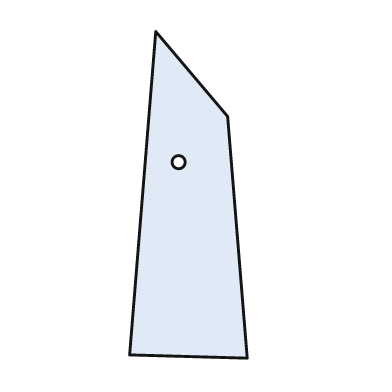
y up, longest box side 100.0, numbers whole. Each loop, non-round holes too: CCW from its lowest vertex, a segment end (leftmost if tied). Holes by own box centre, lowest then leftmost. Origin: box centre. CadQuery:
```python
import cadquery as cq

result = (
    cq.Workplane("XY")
    .moveTo(18.0, -50.0)
    .lineTo(12.0, 24.0)
    .lineTo(-10.0, 50.0)
    .lineTo(-18.0, -49.0)
    .close()
    .moveTo(-3.0, 10.0)
    .circle(2.0)
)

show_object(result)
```